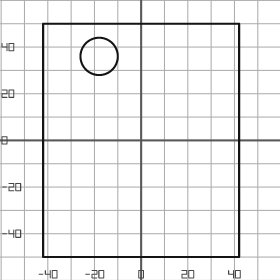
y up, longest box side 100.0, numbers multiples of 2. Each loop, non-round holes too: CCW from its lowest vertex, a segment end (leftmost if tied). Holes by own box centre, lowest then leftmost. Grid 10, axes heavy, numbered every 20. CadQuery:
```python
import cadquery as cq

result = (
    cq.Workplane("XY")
    .moveTo(-42.0, -50.0)
    .lineTo(42.0, -50.0)
    .lineTo(42.0, 50.0)
    .lineTo(-42.0, 50.0)
    .close()
    .moveTo(-18.0, 36.0)
    .circle(8.0)
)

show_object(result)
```